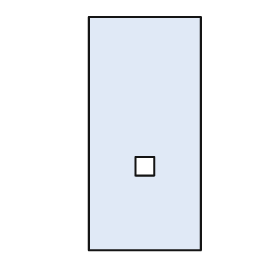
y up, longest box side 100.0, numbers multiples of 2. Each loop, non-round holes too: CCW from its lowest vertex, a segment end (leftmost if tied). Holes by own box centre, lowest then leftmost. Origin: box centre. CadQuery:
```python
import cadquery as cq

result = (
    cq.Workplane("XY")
    .moveTo(-24.0, -50.0)
    .lineTo(24.0, -50.0)
    .lineTo(24.0, 50.0)
    .lineTo(-24.0, 50.0)
    .close()
    .moveTo(-4.0, -18.0)
    .lineTo(4.0, -18.0)
    .lineTo(4.0, -10.0)
    .lineTo(-4.0, -10.0)
    .close()
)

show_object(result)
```